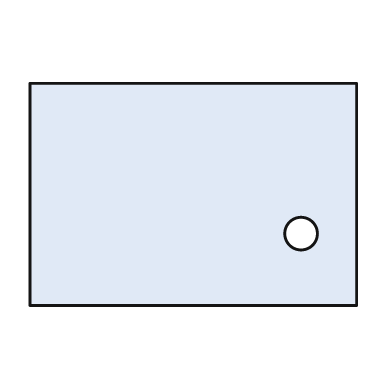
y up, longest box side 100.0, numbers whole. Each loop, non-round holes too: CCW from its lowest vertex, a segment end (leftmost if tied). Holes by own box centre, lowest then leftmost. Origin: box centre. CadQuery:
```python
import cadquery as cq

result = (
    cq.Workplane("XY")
    .moveTo(-50.0, -34.0)
    .lineTo(50.0, -34.0)
    .lineTo(50.0, 34.0)
    .lineTo(-50.0, 34.0)
    .close()
    .moveTo(33.0, -12.0)
    .circle(5.0)
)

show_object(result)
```